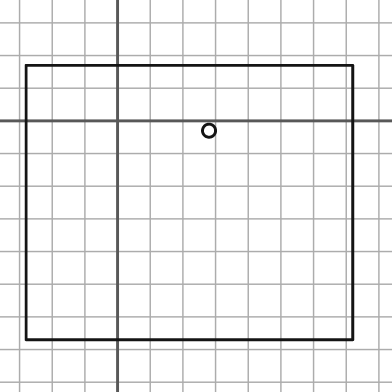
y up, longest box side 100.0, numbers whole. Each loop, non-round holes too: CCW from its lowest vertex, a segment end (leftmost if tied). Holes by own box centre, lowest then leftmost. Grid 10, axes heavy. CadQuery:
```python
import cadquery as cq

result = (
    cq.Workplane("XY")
    .moveTo(-28.0, -67.0)
    .lineTo(72.0, -67.0)
    .lineTo(72.0, 17.0)
    .lineTo(-28.0, 17.0)
    .close()
    .moveTo(28.0, -3.0)
    .circle(2.0)
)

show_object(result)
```